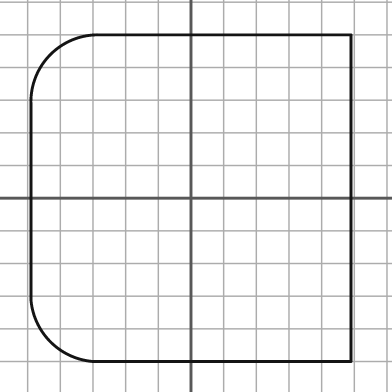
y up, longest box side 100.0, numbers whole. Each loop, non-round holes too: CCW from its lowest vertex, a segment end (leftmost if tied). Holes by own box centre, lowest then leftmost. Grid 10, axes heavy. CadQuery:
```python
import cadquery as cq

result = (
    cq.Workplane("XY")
    .moveTo(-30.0, -50.0)
    .lineTo(49.0, -50.0)
    .lineTo(49.0, 50.0)
    .lineTo(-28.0, 50.0)
    .threePointArc((-43.0, 44.0), (-49.0, 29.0))
    .lineTo(-49.0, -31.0)
    .threePointArc((-43.0, -44.0), (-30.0, -50.0))
    .close()
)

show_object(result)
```